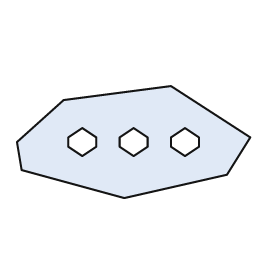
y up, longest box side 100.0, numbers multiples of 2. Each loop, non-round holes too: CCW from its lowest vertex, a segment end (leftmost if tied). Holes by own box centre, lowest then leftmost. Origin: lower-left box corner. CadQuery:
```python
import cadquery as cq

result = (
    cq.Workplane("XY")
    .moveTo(46.0, 0.0)
    .lineTo(90.0, 10.0)
    .lineTo(100.0, 26.0)
    .lineTo(66.0, 48.0)
    .lineTo(20.0, 42.0)
    .lineTo(0.0, 24.0)
    .lineTo(2.0, 12.0)
    .close()
    .moveTo(28.0, 18.0)
    .lineTo(34.0, 22.0)
    .lineTo(34.0, 26.0)
    .lineTo(28.0, 30.0)
    .lineTo(22.0, 26.0)
    .lineTo(22.0, 22.0)
    .close()
    .moveTo(50.0, 18.0)
    .lineTo(56.0, 22.0)
    .lineTo(56.0, 26.0)
    .lineTo(50.0, 30.0)
    .lineTo(44.0, 26.0)
    .lineTo(44.0, 22.0)
    .close()
    .moveTo(72.0, 18.0)
    .lineTo(78.0, 22.0)
    .lineTo(78.0, 26.0)
    .lineTo(72.0, 30.0)
    .lineTo(66.0, 26.0)
    .lineTo(66.0, 22.0)
    .close()
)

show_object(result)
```